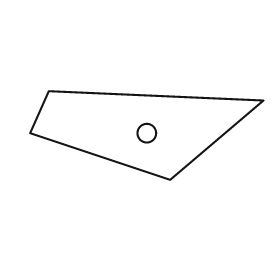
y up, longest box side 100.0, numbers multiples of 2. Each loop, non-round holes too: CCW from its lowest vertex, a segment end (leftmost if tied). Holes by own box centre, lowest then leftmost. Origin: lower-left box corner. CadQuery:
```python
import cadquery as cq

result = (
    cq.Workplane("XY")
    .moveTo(60.0, 0.0)
    .lineTo(100.0, 34.0)
    .lineTo(8.0, 38.0)
    .lineTo(0.0, 20.0)
    .close()
    .moveTo(50.0, 20.0)
    .circle(4.0)
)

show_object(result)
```